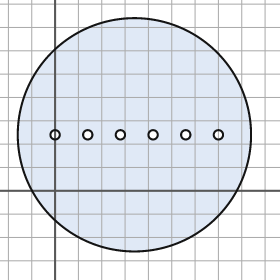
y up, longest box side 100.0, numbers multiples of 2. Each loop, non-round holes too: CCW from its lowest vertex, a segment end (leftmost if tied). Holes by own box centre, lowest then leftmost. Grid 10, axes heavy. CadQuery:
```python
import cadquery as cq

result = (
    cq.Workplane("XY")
    .moveTo(34.0, 24.0)
    .circle(50.0)
    .moveTo(0.0, 24.0)
    .circle(2.0)
    .moveTo(14.0, 24.0)
    .circle(2.0)
    .moveTo(28.0, 24.0)
    .circle(2.0)
    .moveTo(42.0, 24.0)
    .circle(2.0)
    .moveTo(56.0, 24.0)
    .circle(2.0)
    .moveTo(70.0, 24.0)
    .circle(2.0)
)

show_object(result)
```